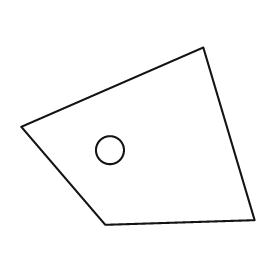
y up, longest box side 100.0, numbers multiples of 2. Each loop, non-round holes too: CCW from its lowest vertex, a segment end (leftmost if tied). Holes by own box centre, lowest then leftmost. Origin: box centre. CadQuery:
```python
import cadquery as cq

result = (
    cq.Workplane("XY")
    .moveTo(-14.0, -38.0)
    .lineTo(50.0, -36.0)
    .lineTo(28.0, 38.0)
    .lineTo(-50.0, 4.0)
    .close()
    .moveTo(-12.0, -6.0)
    .circle(6.0)
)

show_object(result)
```